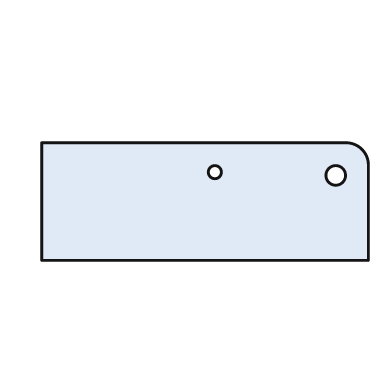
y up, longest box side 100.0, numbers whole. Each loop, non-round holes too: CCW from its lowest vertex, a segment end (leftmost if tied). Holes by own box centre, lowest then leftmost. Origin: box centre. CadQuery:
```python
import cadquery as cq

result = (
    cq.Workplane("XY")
    .moveTo(-50.0, -18.0)
    .lineTo(50.0, -18.0)
    .lineTo(50.0, 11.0)
    .threePointArc((48.0, 16.0), (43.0, 18.0))
    .lineTo(-50.0, 18.0)
    .close()
    .moveTo(40.0, 8.0)
    .circle(3.0)
    .moveTo(3.0, 9.0)
    .circle(2.0)
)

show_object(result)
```